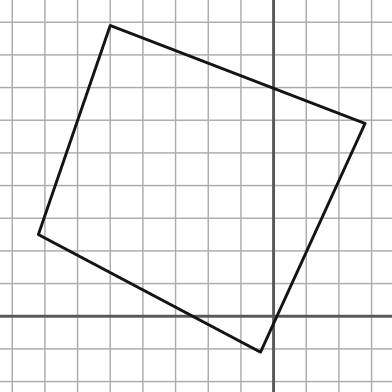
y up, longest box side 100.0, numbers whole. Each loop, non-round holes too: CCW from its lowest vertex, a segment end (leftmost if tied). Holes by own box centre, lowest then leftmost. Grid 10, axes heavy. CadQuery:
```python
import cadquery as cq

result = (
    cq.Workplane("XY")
    .moveTo(-4.0, -11.0)
    .lineTo(28.0, 59.0)
    .lineTo(-50.0, 89.0)
    .lineTo(-72.0, 25.0)
    .close()
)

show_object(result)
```